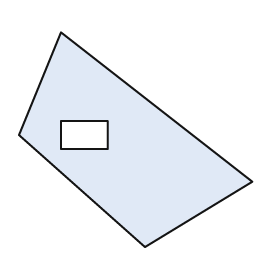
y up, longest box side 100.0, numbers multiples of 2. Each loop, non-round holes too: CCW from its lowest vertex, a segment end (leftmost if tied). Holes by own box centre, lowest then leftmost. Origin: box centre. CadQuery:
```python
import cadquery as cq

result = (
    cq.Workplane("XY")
    .moveTo(4.0, -46.0)
    .lineTo(50.0, -18.0)
    .lineTo(-32.0, 46.0)
    .lineTo(-50.0, 2.0)
    .close()
    .moveTo(-32.0, -4.0)
    .lineTo(-12.0, -4.0)
    .lineTo(-12.0, 8.0)
    .lineTo(-32.0, 8.0)
    .close()
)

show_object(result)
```